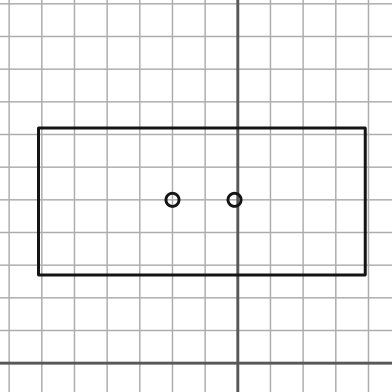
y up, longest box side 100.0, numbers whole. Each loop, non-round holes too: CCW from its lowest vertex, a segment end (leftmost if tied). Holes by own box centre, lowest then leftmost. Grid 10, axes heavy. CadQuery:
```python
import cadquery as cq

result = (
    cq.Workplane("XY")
    .moveTo(-61.0, 27.0)
    .lineTo(39.0, 27.0)
    .lineTo(39.0, 72.0)
    .lineTo(-61.0, 72.0)
    .close()
    .moveTo(-20.0, 50.0)
    .circle(2.0)
    .moveTo(-1.0, 50.0)
    .circle(2.0)
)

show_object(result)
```